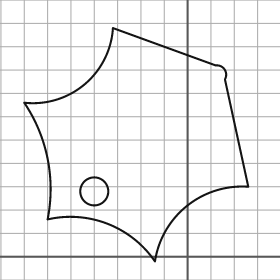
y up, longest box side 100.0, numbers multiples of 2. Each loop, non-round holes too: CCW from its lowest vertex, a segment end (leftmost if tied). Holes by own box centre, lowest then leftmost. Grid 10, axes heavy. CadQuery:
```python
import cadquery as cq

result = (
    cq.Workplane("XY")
    .moveTo(-14.0, -2.0)
    .threePointArc((0.0, 22.0), (26.0, 30.0))
    .lineTo(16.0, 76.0)
    .threePointArc((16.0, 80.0), (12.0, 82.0))
    .lineTo(-32.0, 98.0)
    .threePointArc((-44.0, 74.0), (-70.0, 66.0))
    .threePointArc((-60.0, 42.0), (-60.0, 16.0))
    .threePointArc((-34.0, 14.0), (-14.0, -2.0))
    .close()
    .moveTo(-40.0, 28.0)
    .circle(6.0)
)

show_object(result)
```